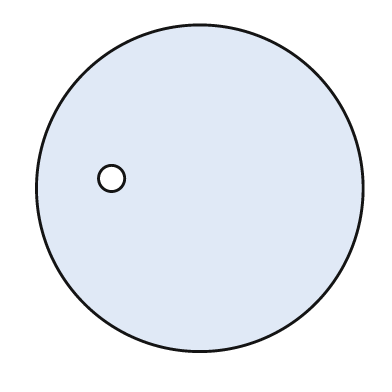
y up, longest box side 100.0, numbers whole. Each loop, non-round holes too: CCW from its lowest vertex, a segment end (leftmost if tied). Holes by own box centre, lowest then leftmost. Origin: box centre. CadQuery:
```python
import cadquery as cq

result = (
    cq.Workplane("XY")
    .moveTo(0.0, 0.0)
    .circle(50.0)
    .moveTo(-27.0, 3.0)
    .circle(4.0)
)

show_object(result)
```